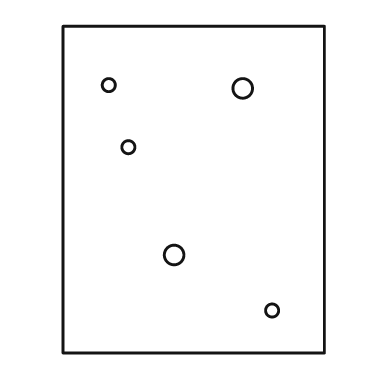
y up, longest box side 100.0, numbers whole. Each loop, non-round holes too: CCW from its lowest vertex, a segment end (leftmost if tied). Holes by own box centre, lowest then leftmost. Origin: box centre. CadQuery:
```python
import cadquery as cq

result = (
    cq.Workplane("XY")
    .moveTo(-40.0, -50.0)
    .lineTo(40.0, -50.0)
    .lineTo(40.0, 50.0)
    .lineTo(-40.0, 50.0)
    .close()
    .moveTo(24.0, -37.0)
    .circle(2.0)
    .moveTo(-6.0, -20.0)
    .circle(3.0)
    .moveTo(-20.0, 13.0)
    .circle(2.0)
    .moveTo(15.0, 31.0)
    .circle(3.0)
    .moveTo(-26.0, 32.0)
    .circle(2.0)
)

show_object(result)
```